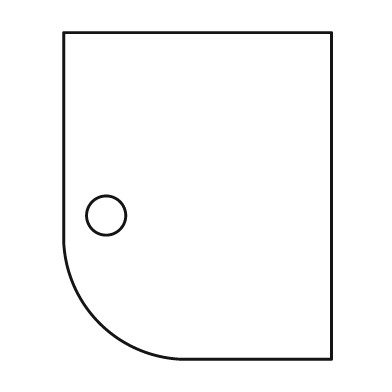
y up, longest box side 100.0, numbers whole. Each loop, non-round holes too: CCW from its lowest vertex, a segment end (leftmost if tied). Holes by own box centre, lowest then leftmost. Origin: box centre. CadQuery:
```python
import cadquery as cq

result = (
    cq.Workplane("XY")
    .moveTo(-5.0, -50.0)
    .lineTo(41.0, -50.0)
    .lineTo(41.0, 50.0)
    .lineTo(-41.0, 50.0)
    .lineTo(-41.0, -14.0)
    .threePointArc((-30.0, -39.0), (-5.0, -50.0))
    .close()
    .moveTo(-28.0, -6.0)
    .circle(6.0)
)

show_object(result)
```